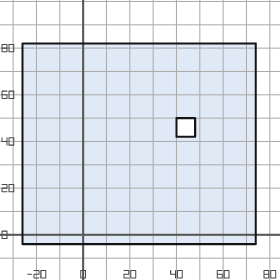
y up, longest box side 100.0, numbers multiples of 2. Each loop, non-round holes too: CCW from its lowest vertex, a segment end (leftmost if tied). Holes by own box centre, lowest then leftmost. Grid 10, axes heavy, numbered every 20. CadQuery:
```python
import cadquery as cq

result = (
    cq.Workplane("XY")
    .moveTo(-26.0, -4.0)
    .lineTo(74.0, -4.0)
    .lineTo(74.0, 82.0)
    .lineTo(-26.0, 82.0)
    .close()
    .moveTo(40.0, 42.0)
    .lineTo(48.0, 42.0)
    .lineTo(48.0, 50.0)
    .lineTo(40.0, 50.0)
    .close()
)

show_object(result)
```